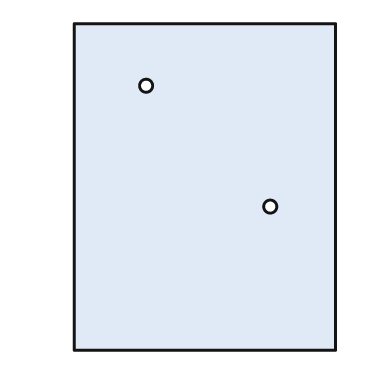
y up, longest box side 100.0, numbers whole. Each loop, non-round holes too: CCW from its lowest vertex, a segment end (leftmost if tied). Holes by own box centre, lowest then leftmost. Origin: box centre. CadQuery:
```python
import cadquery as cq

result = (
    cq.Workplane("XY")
    .moveTo(-40.0, -50.0)
    .lineTo(40.0, -50.0)
    .lineTo(40.0, 50.0)
    .lineTo(-40.0, 50.0)
    .close()
    .moveTo(20.0, -6.0)
    .circle(2.0)
    .moveTo(-18.0, 31.0)
    .circle(2.0)
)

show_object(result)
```